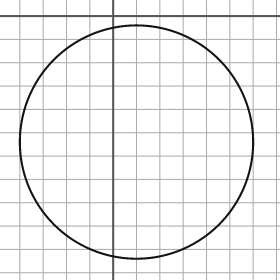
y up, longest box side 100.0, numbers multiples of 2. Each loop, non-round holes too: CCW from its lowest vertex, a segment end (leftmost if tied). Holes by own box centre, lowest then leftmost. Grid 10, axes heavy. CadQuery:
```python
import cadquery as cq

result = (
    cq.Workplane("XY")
    .moveTo(10.0, -54.0)
    .circle(50.0)
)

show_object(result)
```